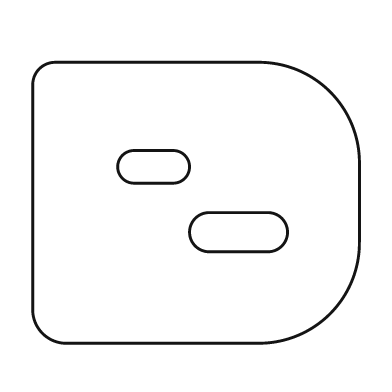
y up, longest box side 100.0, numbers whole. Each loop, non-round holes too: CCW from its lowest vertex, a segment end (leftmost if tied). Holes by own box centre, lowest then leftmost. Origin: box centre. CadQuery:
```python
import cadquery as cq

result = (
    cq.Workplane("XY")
    .moveTo(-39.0, -43.0)
    .lineTo(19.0, -43.0)
    .threePointArc((41.0, -34.0), (50.0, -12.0))
    .lineTo(50.0, 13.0)
    .threePointArc((41.0, 34.0), (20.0, 43.0))
    .lineTo(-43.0, 43.0)
    .threePointArc((-48.0, 41.0), (-50.0, 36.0))
    .lineTo(-50.0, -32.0)
    .threePointArc((-47.0, -40.0), (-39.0, -43.0))
    .close()
    .moveTo(4.0, -15.0)
    .lineTo(22.0, -15.0)
    .threePointArc((28.0, -9.0), (22.0, -3.0))
    .lineTo(4.0, -3.0)
    .threePointArc((-2.0, -9.0), (4.0, -15.0))
    .close()
    .moveTo(-19.0, 6.0)
    .lineTo(-7.0, 6.0)
    .threePointArc((-2.0, 11.0), (-7.0, 16.0))
    .lineTo(-19.0, 16.0)
    .threePointArc((-24.0, 11.0), (-19.0, 6.0))
    .close()
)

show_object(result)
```